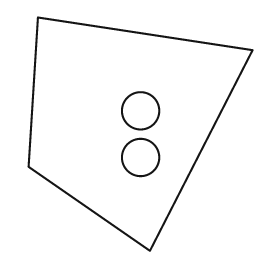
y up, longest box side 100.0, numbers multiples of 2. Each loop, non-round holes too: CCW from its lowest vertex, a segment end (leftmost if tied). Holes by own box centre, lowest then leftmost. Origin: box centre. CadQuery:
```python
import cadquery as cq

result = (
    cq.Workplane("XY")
    .moveTo(4.0, -50.0)
    .lineTo(48.0, 36.0)
    .lineTo(-44.0, 50.0)
    .lineTo(-48.0, -14.0)
    .close()
    .moveTo(0.0, -10.0)
    .circle(8.0)
    .moveTo(0.0, 10.0)
    .circle(8.0)
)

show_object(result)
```